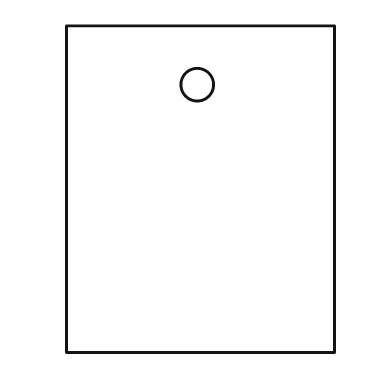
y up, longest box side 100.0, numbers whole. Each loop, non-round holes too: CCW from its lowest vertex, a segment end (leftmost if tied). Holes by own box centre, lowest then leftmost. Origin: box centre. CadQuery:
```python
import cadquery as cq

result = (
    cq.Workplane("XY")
    .moveTo(-41.0, -50.0)
    .lineTo(41.0, -50.0)
    .lineTo(41.0, 50.0)
    .lineTo(-41.0, 50.0)
    .close()
    .moveTo(-1.0, 32.0)
    .circle(5.0)
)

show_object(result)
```